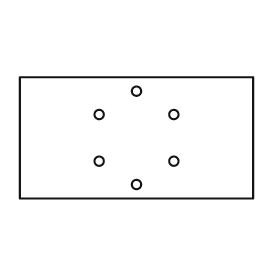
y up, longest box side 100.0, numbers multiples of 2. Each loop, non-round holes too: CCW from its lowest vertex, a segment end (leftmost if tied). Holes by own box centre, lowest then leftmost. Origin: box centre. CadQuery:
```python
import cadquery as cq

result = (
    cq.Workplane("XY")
    .moveTo(-50.0, -26.0)
    .lineTo(50.0, -26.0)
    .lineTo(50.0, 26.0)
    .lineTo(-50.0, 26.0)
    .close()
    .moveTo(0.0, -20.0)
    .circle(2.0)
    .moveTo(-16.0, -10.0)
    .circle(2.0)
    .moveTo(16.0, -10.0)
    .circle(2.0)
    .moveTo(-16.0, 10.0)
    .circle(2.0)
    .moveTo(16.0, 10.0)
    .circle(2.0)
    .moveTo(0.0, 20.0)
    .circle(2.0)
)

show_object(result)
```